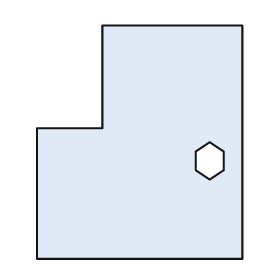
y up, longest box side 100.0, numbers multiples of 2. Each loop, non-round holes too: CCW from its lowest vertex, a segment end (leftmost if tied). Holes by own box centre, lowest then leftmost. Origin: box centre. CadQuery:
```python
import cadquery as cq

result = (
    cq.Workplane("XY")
    .moveTo(-44.0, -50.0)
    .lineTo(44.0, -50.0)
    .lineTo(44.0, 50.0)
    .lineTo(-16.0, 50.0)
    .lineTo(-16.0, 6.0)
    .lineTo(-44.0, 6.0)
    .close()
    .moveTo(30.0, -16.0)
    .lineTo(36.0, -12.0)
    .lineTo(36.0, -4.0)
    .lineTo(30.0, 0.0)
    .lineTo(24.0, -4.0)
    .lineTo(24.0, -12.0)
    .close()
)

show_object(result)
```